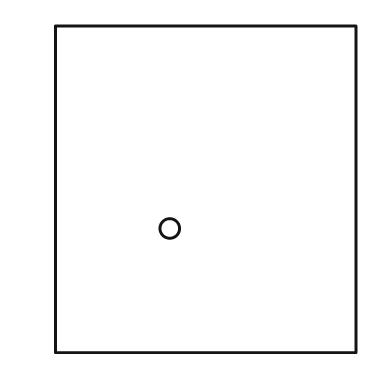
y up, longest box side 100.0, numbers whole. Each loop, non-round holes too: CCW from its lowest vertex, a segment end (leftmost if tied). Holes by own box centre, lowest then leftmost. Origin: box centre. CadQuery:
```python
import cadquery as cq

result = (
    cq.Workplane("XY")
    .moveTo(-46.0, -50.0)
    .lineTo(46.0, -50.0)
    .lineTo(46.0, 50.0)
    .lineTo(-46.0, 50.0)
    .close()
    .moveTo(-11.0, -12.0)
    .circle(3.0)
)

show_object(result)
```